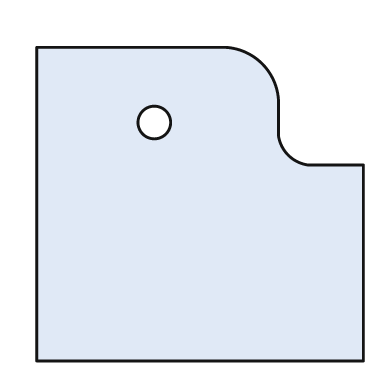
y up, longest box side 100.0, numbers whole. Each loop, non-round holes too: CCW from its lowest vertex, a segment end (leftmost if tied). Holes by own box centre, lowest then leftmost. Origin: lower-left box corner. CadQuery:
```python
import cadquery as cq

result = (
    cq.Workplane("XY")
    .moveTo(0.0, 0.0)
    .lineTo(100.0, 0.0)
    .lineTo(100.0, 60.0)
    .lineTo(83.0, 60.0)
    .threePointArc((77.0, 63.0), (74.0, 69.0))
    .lineTo(74.0, 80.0)
    .threePointArc((69.0, 91.0), (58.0, 96.0))
    .lineTo(0.0, 96.0)
    .close()
    .moveTo(36.0, 73.0)
    .circle(5.0)
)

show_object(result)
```